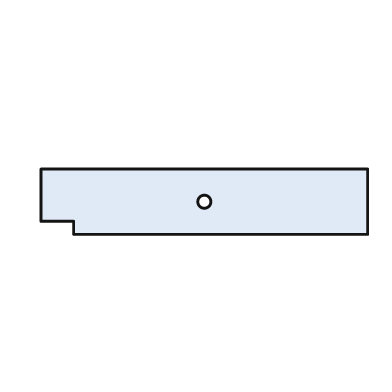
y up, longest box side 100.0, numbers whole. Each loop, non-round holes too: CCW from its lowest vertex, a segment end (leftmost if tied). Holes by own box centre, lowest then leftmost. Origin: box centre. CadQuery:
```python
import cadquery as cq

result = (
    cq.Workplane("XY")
    .moveTo(-40.0, -10.0)
    .lineTo(50.0, -10.0)
    .lineTo(50.0, 10.0)
    .lineTo(-50.0, 10.0)
    .lineTo(-50.0, -6.0)
    .lineTo(-40.0, -6.0)
    .close()
    .moveTo(0.0, 0.0)
    .circle(2.0)
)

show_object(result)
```